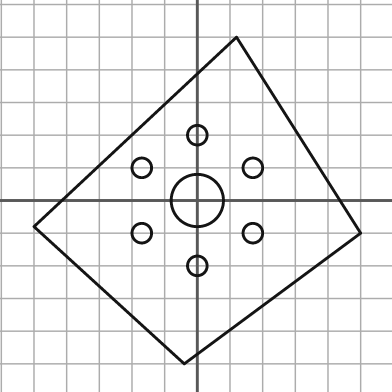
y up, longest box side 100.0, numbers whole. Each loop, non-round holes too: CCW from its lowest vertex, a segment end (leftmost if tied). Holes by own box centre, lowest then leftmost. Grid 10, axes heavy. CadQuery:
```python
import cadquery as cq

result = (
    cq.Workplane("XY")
    .moveTo(-4.0, -50.0)
    .lineTo(50.0, -10.0)
    .lineTo(12.0, 50.0)
    .lineTo(-50.0, -8.0)
    .close()
    .moveTo(0.0, -20.0)
    .circle(3.0)
    .moveTo(-17.0, -10.0)
    .circle(3.0)
    .moveTo(17.0, -10.0)
    .circle(3.0)
    .moveTo(0.0, 0.0)
    .circle(8.0)
    .moveTo(-17.0, 10.0)
    .circle(3.0)
    .moveTo(17.0, 10.0)
    .circle(3.0)
    .moveTo(0.0, 20.0)
    .circle(3.0)
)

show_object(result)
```